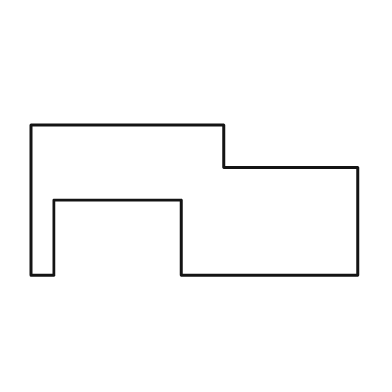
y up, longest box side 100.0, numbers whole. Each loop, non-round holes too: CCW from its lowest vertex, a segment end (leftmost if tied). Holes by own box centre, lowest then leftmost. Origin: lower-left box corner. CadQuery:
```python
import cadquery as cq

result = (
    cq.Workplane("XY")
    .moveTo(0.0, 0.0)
    .lineTo(7.0, 0.0)
    .lineTo(7.0, 23.0)
    .lineTo(46.0, 23.0)
    .lineTo(46.0, 0.0)
    .lineTo(100.0, 0.0)
    .lineTo(100.0, 33.0)
    .lineTo(59.0, 33.0)
    .lineTo(59.0, 46.0)
    .lineTo(0.0, 46.0)
    .close()
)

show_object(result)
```